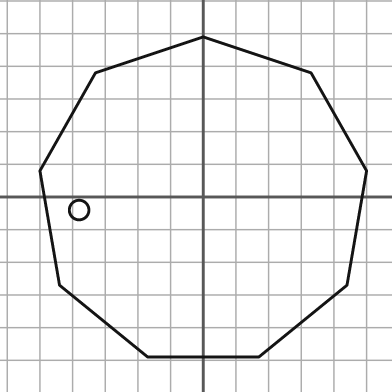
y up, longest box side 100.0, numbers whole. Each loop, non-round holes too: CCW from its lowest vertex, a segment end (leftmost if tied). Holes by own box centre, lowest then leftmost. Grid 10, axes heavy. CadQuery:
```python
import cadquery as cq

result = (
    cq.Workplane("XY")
    .moveTo(-17.0, -49.0)
    .lineTo(17.0, -49.0)
    .lineTo(44.0, -27.0)
    .lineTo(50.0, 8.0)
    .lineTo(33.0, 38.0)
    .lineTo(0.0, 49.0)
    .lineTo(-33.0, 38.0)
    .lineTo(-50.0, 8.0)
    .lineTo(-44.0, -27.0)
    .close()
    .moveTo(-38.0, -4.0)
    .circle(3.0)
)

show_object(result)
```